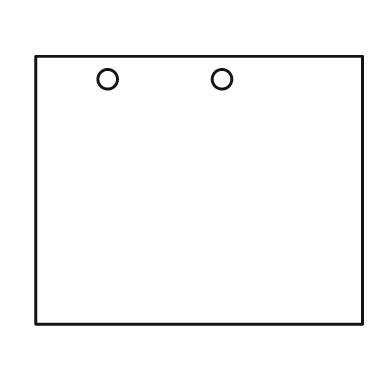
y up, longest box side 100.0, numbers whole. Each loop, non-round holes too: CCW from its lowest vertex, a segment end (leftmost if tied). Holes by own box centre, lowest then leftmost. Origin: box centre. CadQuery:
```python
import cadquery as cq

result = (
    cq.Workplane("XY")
    .moveTo(-50.0, -41.0)
    .lineTo(50.0, -41.0)
    .lineTo(50.0, 41.0)
    .lineTo(-50.0, 41.0)
    .close()
    .moveTo(-28.0, 34.0)
    .circle(3.0)
    .moveTo(7.0, 34.0)
    .circle(3.0)
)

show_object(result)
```